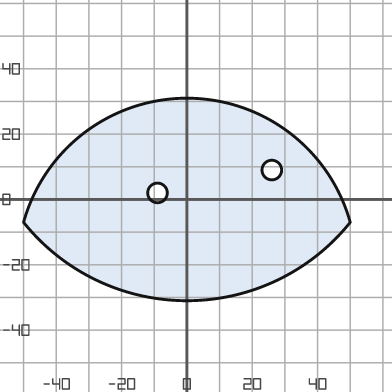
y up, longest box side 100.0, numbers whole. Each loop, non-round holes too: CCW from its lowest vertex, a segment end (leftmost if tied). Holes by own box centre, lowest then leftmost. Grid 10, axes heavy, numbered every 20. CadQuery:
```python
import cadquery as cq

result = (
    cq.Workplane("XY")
    .moveTo(-50.0, -7.0)
    .threePointArc((0.0, -31.0), (50.0, -7.0))
    .threePointArc((0.0, 31.0), (-50.0, -7.0))
    .close()
    .moveTo(-9.0, 2.0)
    .circle(3.0)
    .moveTo(26.0, 9.0)
    .circle(3.0)
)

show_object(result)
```